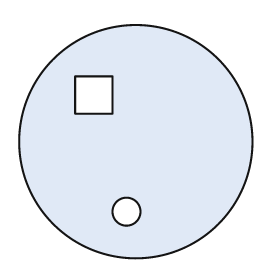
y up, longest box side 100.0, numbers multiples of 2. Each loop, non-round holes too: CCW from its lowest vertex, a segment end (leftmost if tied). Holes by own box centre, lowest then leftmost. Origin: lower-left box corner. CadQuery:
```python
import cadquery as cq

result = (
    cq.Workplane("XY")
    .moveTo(50.0, 50.0)
    .circle(50.0)
    .moveTo(46.0, 20.0)
    .circle(6.0)
    .moveTo(24.0, 62.0)
    .lineTo(40.0, 62.0)
    .lineTo(40.0, 78.0)
    .lineTo(24.0, 78.0)
    .close()
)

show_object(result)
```